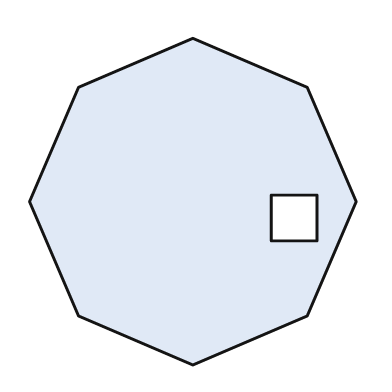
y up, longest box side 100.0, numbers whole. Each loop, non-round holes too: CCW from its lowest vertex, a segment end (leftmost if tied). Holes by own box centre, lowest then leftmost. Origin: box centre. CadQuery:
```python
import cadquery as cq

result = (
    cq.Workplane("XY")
    .moveTo(0.0, -50.0)
    .lineTo(35.0, -35.0)
    .lineTo(50.0, 0.0)
    .lineTo(35.0, 35.0)
    .lineTo(0.0, 50.0)
    .lineTo(-35.0, 35.0)
    .lineTo(-50.0, 0.0)
    .lineTo(-35.0, -35.0)
    .close()
    .moveTo(24.0, -12.0)
    .lineTo(38.0, -12.0)
    .lineTo(38.0, 2.0)
    .lineTo(24.0, 2.0)
    .close()
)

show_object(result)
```